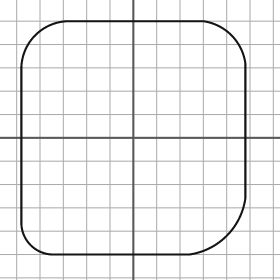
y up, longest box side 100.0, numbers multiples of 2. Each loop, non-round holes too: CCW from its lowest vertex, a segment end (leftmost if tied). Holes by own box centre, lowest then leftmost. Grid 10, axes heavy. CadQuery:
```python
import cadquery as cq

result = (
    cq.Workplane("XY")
    .moveTo(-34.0, -50.0)
    .lineTo(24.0, -50.0)
    .threePointArc((40.0, -42.0), (48.0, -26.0))
    .lineTo(48.0, 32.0)
    .threePointArc((42.0, 44.0), (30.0, 50.0))
    .lineTo(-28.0, 50.0)
    .threePointArc((-42.0, 44.0), (-48.0, 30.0))
    .lineTo(-48.0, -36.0)
    .threePointArc((-44.0, -46.0), (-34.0, -50.0))
    .close()
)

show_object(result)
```